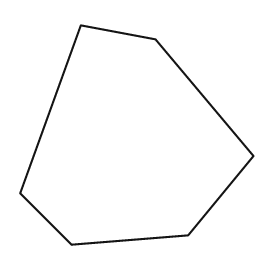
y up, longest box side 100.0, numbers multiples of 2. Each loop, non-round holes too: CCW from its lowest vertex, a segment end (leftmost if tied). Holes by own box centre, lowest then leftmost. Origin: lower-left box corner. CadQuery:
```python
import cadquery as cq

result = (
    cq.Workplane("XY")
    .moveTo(22.0, 0.0)
    .lineTo(72.0, 4.0)
    .lineTo(100.0, 38.0)
    .lineTo(58.0, 88.0)
    .lineTo(26.0, 94.0)
    .lineTo(0.0, 22.0)
    .close()
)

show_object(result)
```